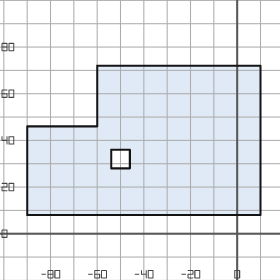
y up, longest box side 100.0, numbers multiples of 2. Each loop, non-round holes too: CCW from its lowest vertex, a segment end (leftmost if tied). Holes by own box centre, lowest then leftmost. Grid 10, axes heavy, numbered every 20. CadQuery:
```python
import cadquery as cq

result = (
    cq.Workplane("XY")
    .moveTo(-90.0, 8.0)
    .lineTo(10.0, 8.0)
    .lineTo(10.0, 72.0)
    .lineTo(-60.0, 72.0)
    .lineTo(-60.0, 46.0)
    .lineTo(-90.0, 46.0)
    .close()
    .moveTo(-54.0, 28.0)
    .lineTo(-46.0, 28.0)
    .lineTo(-46.0, 36.0)
    .lineTo(-54.0, 36.0)
    .close()
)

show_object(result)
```